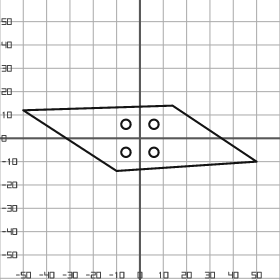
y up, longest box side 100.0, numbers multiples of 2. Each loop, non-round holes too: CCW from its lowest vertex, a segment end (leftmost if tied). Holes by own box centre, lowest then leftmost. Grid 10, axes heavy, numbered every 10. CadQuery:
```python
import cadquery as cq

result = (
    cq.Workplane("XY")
    .moveTo(-10.0, -14.0)
    .lineTo(50.0, -10.0)
    .lineTo(14.0, 14.0)
    .lineTo(-50.0, 12.0)
    .close()
    .moveTo(-6.0, -6.0)
    .circle(2.0)
    .moveTo(6.0, -6.0)
    .circle(2.0)
    .moveTo(-6.0, 6.0)
    .circle(2.0)
    .moveTo(6.0, 6.0)
    .circle(2.0)
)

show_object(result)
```